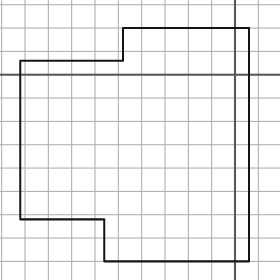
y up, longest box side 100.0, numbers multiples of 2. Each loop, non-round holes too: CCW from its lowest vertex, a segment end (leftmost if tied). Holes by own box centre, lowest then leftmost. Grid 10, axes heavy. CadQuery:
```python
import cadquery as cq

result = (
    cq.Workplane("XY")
    .moveTo(-56.0, -80.0)
    .lineTo(6.0, -80.0)
    .lineTo(6.0, 20.0)
    .lineTo(-48.0, 20.0)
    .lineTo(-48.0, 6.0)
    .lineTo(-92.0, 6.0)
    .lineTo(-92.0, -62.0)
    .lineTo(-56.0, -62.0)
    .close()
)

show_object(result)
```